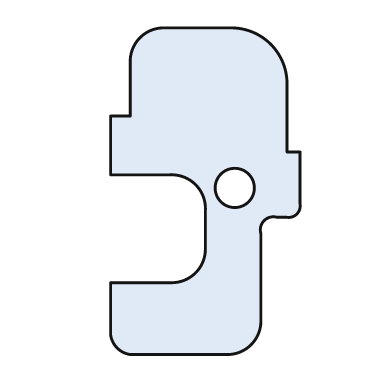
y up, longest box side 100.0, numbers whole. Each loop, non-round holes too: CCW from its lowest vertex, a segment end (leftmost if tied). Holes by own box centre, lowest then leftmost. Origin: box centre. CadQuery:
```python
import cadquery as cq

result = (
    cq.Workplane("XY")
    .moveTo(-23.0, -50.0)
    .lineTo(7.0, -50.0)
    .threePointArc((14.0, -47.0), (17.0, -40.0))
    .lineTo(17.0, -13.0)
    .threePointArc((18.0, -9.0), (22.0, -8.0))
    .lineTo(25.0, -8.0)
    .threePointArc((28.0, -7.0), (29.0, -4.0))
    .lineTo(29.0, 12.0)
    .lineTo(25.0, 12.0)
    .lineTo(25.0, 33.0)
    .threePointArc((20.0, 45.0), (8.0, 50.0))
    .lineTo(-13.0, 50.0)
    .threePointArc((-20.0, 47.0), (-23.0, 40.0))
    .lineTo(-23.0, 23.0)
    .lineTo(-29.0, 23.0)
    .lineTo(-29.0, 5.0)
    .lineTo(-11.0, 5.0)
    .threePointArc((-3.0, 2.0), (0.0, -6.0))
    .lineTo(0.0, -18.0)
    .threePointArc((-3.0, -25.0), (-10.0, -28.0))
    .lineTo(-29.0, -28.0)
    .lineTo(-29.0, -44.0)
    .threePointArc((-27.0, -48.0), (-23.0, -50.0))
    .close()
    .moveTo(9.0, 1.0)
    .circle(6.0)
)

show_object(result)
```